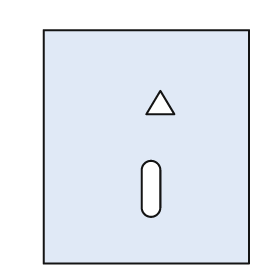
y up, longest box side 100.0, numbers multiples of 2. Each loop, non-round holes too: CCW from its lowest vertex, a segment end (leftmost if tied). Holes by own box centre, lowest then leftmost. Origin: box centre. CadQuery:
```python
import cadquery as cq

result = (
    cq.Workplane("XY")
    .moveTo(-44.0, -50.0)
    .lineTo(44.0, -50.0)
    .lineTo(44.0, 50.0)
    .lineTo(-44.0, 50.0)
    .close()
    .moveTo(-2.0, -26.0)
    .threePointArc((2.0, -30.0), (6.0, -26.0))
    .lineTo(6.0, -10.0)
    .threePointArc((2.0, -6.0), (-2.0, -10.0))
    .close()
    .moveTo(0.0, 14.0)
    .lineTo(12.0, 14.0)
    .lineTo(6.0, 24.0)
    .close()
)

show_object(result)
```